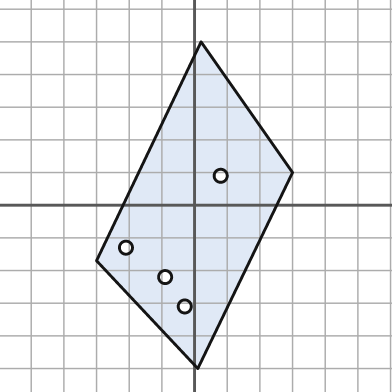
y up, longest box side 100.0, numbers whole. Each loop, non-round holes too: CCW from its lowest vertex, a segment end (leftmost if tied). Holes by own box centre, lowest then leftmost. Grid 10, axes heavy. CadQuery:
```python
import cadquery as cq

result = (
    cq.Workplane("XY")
    .moveTo(1.0, -50.0)
    .lineTo(30.0, 10.0)
    .lineTo(2.0, 50.0)
    .lineTo(-30.0, -17.0)
    .close()
    .moveTo(-3.0, -31.0)
    .circle(2.0)
    .moveTo(-9.0, -22.0)
    .circle(2.0)
    .moveTo(-21.0, -13.0)
    .circle(2.0)
    .moveTo(8.0, 9.0)
    .circle(2.0)
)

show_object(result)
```